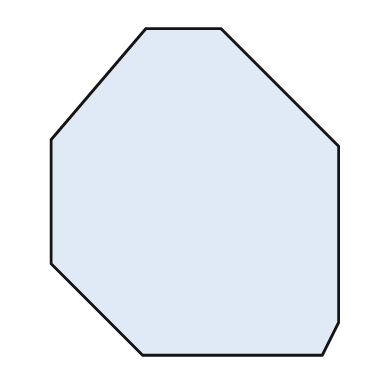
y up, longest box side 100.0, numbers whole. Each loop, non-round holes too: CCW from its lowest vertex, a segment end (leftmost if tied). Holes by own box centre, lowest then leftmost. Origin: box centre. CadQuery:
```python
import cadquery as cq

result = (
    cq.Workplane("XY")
    .moveTo(-16.0, -50.0)
    .lineTo(39.0, -50.0)
    .lineTo(44.0, -40.0)
    .lineTo(44.0, 14.0)
    .lineTo(8.0, 50.0)
    .lineTo(-15.0, 50.0)
    .lineTo(-44.0, 16.0)
    .lineTo(-44.0, -22.0)
    .close()
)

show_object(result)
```